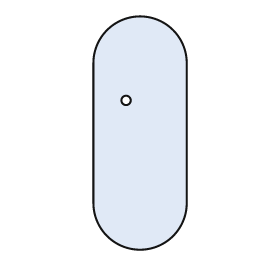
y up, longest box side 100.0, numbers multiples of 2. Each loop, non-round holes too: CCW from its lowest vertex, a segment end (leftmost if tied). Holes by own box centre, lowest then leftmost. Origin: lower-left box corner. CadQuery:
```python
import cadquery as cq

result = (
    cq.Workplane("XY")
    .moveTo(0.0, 20.0)
    .threePointArc((20.0, 0.0), (40.0, 20.0))
    .lineTo(40.0, 80.0)
    .threePointArc((20.0, 100.0), (0.0, 80.0))
    .close()
    .moveTo(14.0, 64.0)
    .circle(2.0)
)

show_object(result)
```